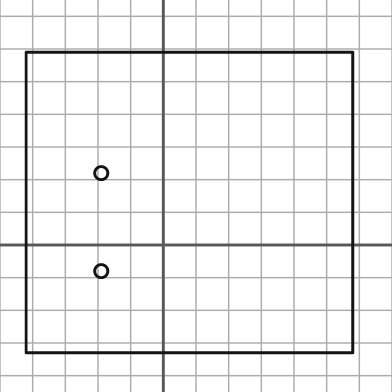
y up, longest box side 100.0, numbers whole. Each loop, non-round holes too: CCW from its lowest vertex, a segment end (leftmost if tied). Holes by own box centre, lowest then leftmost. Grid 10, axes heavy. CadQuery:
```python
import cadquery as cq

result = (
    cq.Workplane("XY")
    .moveTo(-42.0, -33.0)
    .lineTo(58.0, -33.0)
    .lineTo(58.0, 59.0)
    .lineTo(-42.0, 59.0)
    .close()
    .moveTo(-19.0, -8.0)
    .circle(2.0)
    .moveTo(-19.0, 22.0)
    .circle(2.0)
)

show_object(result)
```